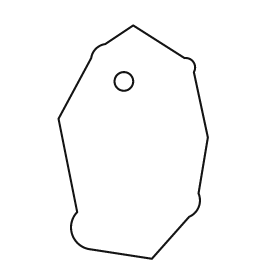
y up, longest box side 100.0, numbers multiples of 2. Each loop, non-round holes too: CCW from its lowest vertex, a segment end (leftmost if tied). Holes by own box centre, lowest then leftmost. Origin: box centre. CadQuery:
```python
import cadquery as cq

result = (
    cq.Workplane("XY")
    .moveTo(8.0, -50.0)
    .lineTo(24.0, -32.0)
    .threePointArc((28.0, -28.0), (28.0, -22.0))
    .lineTo(32.0, 2.0)
    .lineTo(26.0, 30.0)
    .threePointArc((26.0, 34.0), (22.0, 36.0))
    .lineTo(0.0, 50.0)
    .lineTo(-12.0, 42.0)
    .threePointArc((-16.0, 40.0), (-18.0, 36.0))
    .lineTo(-32.0, 10.0)
    .lineTo(-24.0, -30.0)
    .threePointArc((-26.0, -40.0), (-18.0, -46.0))
    .close()
    .moveTo(-4.0, 26.0)
    .circle(4.0)
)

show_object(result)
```